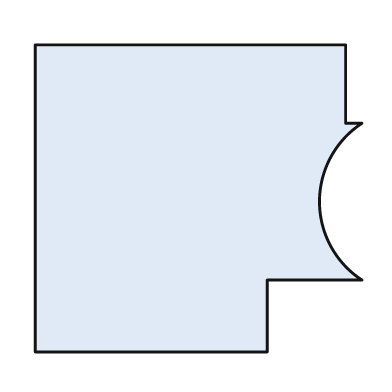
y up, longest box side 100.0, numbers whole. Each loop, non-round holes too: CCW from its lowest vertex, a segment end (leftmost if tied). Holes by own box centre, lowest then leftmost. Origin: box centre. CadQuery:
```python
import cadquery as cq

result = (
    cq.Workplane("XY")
    .moveTo(-50.0, -47.0)
    .lineTo(21.0, -47.0)
    .lineTo(21.0, -25.0)
    .lineTo(50.0, -25.0)
    .threePointArc((37.0, -1.0), (50.0, 23.0))
    .lineTo(45.0, 23.0)
    .lineTo(45.0, 47.0)
    .lineTo(-50.0, 47.0)
    .close()
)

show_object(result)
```